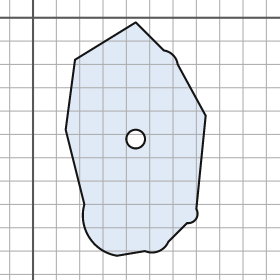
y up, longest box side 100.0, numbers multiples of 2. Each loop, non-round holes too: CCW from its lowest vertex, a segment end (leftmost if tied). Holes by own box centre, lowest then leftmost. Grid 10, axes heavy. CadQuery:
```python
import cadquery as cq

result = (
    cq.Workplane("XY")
    .moveTo(36.0, -102.0)
    .lineTo(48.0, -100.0)
    .threePointArc((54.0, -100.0), (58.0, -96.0))
    .lineTo(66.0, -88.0)
    .threePointArc((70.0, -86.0), (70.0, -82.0))
    .lineTo(74.0, -42.0)
    .lineTo(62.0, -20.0)
    .threePointArc((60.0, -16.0), (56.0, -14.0))
    .lineTo(44.0, -2.0)
    .lineTo(18.0, -18.0)
    .lineTo(14.0, -48.0)
    .lineTo(22.0, -80.0)
    .threePointArc((24.0, -94.0), (36.0, -102.0))
    .close()
    .moveTo(44.0, -52.0)
    .circle(4.0)
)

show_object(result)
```